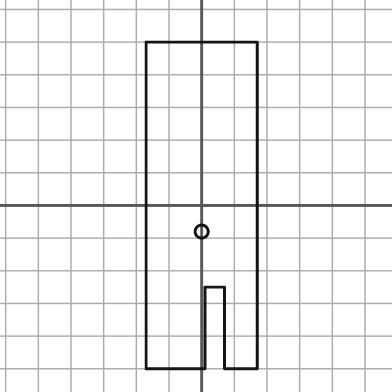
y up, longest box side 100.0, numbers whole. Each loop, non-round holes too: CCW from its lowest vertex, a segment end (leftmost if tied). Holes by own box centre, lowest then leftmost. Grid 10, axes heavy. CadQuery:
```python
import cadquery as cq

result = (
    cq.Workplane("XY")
    .moveTo(-17.0, -50.0)
    .lineTo(1.0, -50.0)
    .lineTo(1.0, -25.0)
    .lineTo(7.0, -25.0)
    .lineTo(7.0, -50.0)
    .lineTo(17.0, -50.0)
    .lineTo(17.0, 50.0)
    .lineTo(-17.0, 50.0)
    .close()
    .moveTo(0.0, -8.0)
    .circle(2.0)
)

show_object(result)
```